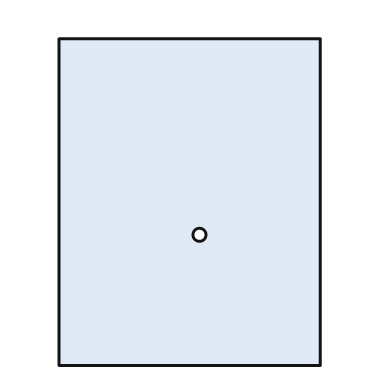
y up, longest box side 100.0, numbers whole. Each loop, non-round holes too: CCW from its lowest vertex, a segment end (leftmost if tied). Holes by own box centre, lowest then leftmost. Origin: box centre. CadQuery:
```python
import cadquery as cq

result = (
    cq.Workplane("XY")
    .moveTo(-40.0, -50.0)
    .lineTo(40.0, -50.0)
    .lineTo(40.0, 50.0)
    .lineTo(-40.0, 50.0)
    .close()
    .moveTo(3.0, -10.0)
    .circle(2.0)
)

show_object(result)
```